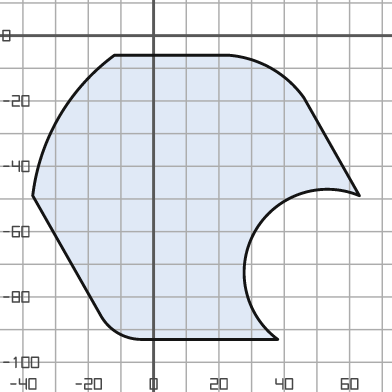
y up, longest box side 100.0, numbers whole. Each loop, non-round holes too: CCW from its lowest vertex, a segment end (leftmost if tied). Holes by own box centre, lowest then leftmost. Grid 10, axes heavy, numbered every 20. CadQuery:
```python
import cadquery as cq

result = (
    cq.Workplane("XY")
    .moveTo(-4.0, -93.0)
    .lineTo(38.0, -93.0)
    .threePointArc((31.0, -60.0), (63.0, -49.0))
    .lineTo(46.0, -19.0)
    .threePointArc((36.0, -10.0), (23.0, -6.0))
    .lineTo(-12.0, -6.0)
    .threePointArc((-29.0, -25.0), (-37.0, -49.0))
    .lineTo(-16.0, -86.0)
    .threePointArc((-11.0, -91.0), (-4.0, -93.0))
    .close()
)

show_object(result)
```